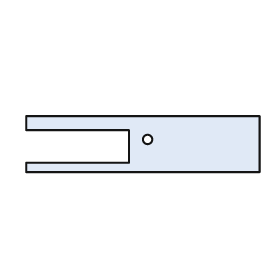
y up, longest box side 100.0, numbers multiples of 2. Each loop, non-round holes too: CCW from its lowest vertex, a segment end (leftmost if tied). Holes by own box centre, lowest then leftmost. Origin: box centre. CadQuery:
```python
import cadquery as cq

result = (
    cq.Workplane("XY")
    .moveTo(-50.0, -12.0)
    .lineTo(50.0, -12.0)
    .lineTo(50.0, 12.0)
    .lineTo(-50.0, 12.0)
    .lineTo(-50.0, 6.0)
    .lineTo(-6.0, 6.0)
    .lineTo(-6.0, -8.0)
    .lineTo(-50.0, -8.0)
    .close()
    .moveTo(2.0, 2.0)
    .circle(2.0)
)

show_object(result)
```